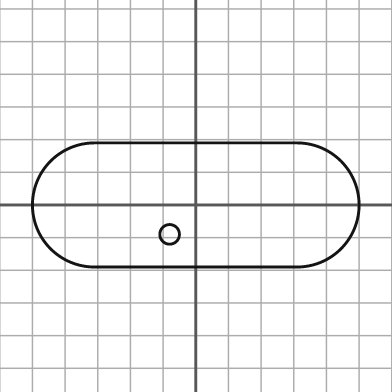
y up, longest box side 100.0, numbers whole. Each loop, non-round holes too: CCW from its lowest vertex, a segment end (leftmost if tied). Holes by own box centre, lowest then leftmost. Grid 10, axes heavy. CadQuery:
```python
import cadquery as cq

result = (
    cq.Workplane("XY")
    .moveTo(-31.0, -19.0)
    .lineTo(31.0, -19.0)
    .threePointArc((50.0, 0.0), (31.0, 19.0))
    .lineTo(-31.0, 19.0)
    .threePointArc((-50.0, 0.0), (-31.0, -19.0))
    .close()
    .moveTo(-8.0, -9.0)
    .circle(3.0)
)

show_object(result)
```